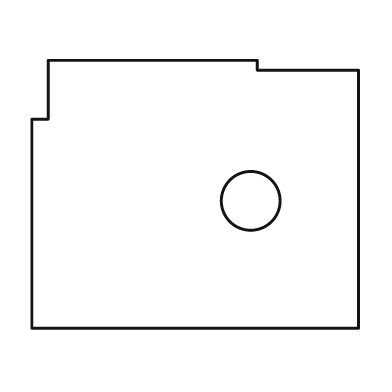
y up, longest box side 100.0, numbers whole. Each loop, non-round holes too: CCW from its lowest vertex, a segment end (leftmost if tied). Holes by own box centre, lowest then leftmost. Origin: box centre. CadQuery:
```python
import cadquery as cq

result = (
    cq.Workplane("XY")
    .moveTo(-50.0, -41.0)
    .lineTo(50.0, -41.0)
    .lineTo(50.0, 38.0)
    .lineTo(19.0, 38.0)
    .lineTo(19.0, 41.0)
    .lineTo(-45.0, 41.0)
    .lineTo(-45.0, 23.0)
    .lineTo(-50.0, 23.0)
    .close()
    .moveTo(17.0, -2.0)
    .circle(9.0)
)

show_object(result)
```